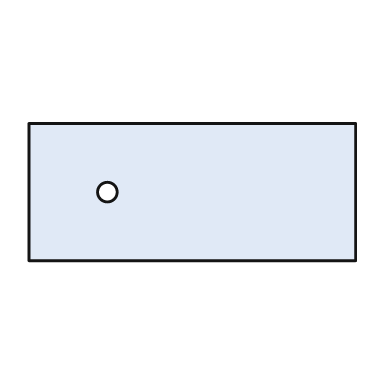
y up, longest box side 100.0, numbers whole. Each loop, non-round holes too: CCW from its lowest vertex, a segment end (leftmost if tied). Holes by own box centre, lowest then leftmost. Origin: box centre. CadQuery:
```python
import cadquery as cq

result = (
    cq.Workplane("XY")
    .moveTo(-50.0, -21.0)
    .lineTo(50.0, -21.0)
    .lineTo(50.0, 21.0)
    .lineTo(-50.0, 21.0)
    .close()
    .moveTo(-26.0, 0.0)
    .circle(3.0)
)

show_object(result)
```